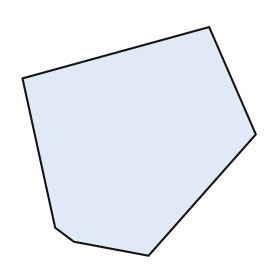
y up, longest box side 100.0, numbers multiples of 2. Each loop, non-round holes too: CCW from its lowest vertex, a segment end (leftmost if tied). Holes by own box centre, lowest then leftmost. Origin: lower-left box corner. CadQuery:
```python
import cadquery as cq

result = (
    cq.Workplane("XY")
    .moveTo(54.0, 0.0)
    .lineTo(100.0, 52.0)
    .lineTo(80.0, 98.0)
    .lineTo(0.0, 76.0)
    .lineTo(14.0, 12.0)
    .lineTo(22.0, 6.0)
    .close()
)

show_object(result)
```